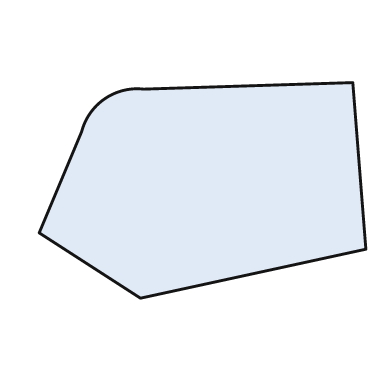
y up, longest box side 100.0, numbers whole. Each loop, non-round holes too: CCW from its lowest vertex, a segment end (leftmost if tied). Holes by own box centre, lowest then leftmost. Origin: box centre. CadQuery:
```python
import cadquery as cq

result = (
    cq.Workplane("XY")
    .moveTo(-19.0, -33.0)
    .lineTo(50.0, -18.0)
    .lineTo(46.0, 33.0)
    .lineTo(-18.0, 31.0)
    .threePointArc((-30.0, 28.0), (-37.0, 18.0))
    .lineTo(-50.0, -13.0)
    .close()
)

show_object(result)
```